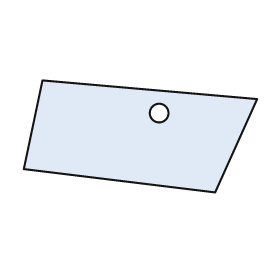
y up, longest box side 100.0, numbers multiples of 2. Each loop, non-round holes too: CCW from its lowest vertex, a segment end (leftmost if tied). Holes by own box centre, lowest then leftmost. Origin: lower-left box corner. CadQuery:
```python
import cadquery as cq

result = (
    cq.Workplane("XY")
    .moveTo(82.0, 0.0)
    .lineTo(100.0, 40.0)
    .lineTo(8.0, 48.0)
    .lineTo(0.0, 10.0)
    .close()
    .moveTo(58.0, 34.0)
    .circle(4.0)
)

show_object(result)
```